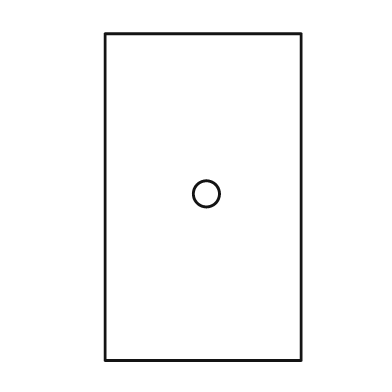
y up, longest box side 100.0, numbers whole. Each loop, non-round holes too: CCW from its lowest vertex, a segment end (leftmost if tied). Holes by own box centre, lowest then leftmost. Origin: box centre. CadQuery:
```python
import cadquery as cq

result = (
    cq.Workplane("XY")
    .moveTo(-30.0, -50.0)
    .lineTo(30.0, -50.0)
    .lineTo(30.0, 50.0)
    .lineTo(-30.0, 50.0)
    .close()
    .moveTo(1.0, 1.0)
    .circle(4.0)
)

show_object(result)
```